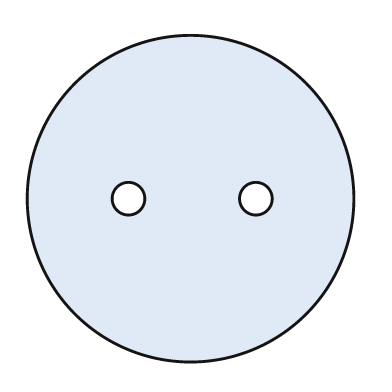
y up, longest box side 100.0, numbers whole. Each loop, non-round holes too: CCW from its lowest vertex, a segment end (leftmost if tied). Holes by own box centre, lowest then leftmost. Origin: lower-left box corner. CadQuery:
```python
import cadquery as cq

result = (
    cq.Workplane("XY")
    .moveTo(50.0, 50.0)
    .circle(50.0)
    .moveTo(31.0, 50.0)
    .circle(5.0)
    .moveTo(70.0, 50.0)
    .circle(5.0)
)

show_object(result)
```